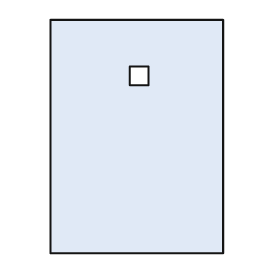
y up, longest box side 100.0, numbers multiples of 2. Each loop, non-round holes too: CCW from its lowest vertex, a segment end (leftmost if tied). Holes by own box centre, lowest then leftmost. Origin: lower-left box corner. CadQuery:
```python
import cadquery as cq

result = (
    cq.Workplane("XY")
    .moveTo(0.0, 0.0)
    .lineTo(74.0, 0.0)
    .lineTo(74.0, 100.0)
    .lineTo(0.0, 100.0)
    .close()
    .moveTo(34.0, 72.0)
    .lineTo(42.0, 72.0)
    .lineTo(42.0, 80.0)
    .lineTo(34.0, 80.0)
    .close()
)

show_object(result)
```